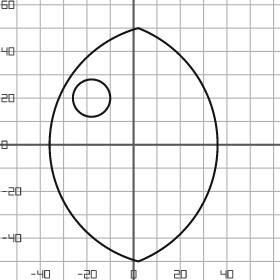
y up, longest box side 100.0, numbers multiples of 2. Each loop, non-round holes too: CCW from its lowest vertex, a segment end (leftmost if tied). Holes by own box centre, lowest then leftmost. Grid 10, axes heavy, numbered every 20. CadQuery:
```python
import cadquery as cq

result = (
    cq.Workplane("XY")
    .moveTo(2.0, -50.0)
    .threePointArc((36.0, 0.0), (2.0, 50.0))
    .threePointArc((-36.0, 0.0), (2.0, -50.0))
    .close()
    .moveTo(-18.0, 20.0)
    .circle(8.0)
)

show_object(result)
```